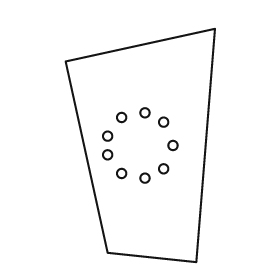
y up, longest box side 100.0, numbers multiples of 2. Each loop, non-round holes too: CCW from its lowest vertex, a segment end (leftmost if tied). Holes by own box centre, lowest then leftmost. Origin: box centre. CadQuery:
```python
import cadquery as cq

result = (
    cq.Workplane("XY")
    .moveTo(24.0, -50.0)
    .lineTo(32.0, 50.0)
    .lineTo(-32.0, 36.0)
    .lineTo(-14.0, -46.0)
    .close()
    .moveTo(2.0, -14.0)
    .circle(2.0)
    .moveTo(-8.0, -12.0)
    .circle(2.0)
    .moveTo(10.0, -10.0)
    .circle(2.0)
    .moveTo(-14.0, -4.0)
    .circle(2.0)
    .moveTo(14.0, 0.0)
    .circle(2.0)
    .moveTo(-14.0, 4.0)
    .circle(2.0)
    .moveTo(10.0, 10.0)
    .circle(2.0)
    .moveTo(-8.0, 12.0)
    .circle(2.0)
    .moveTo(2.0, 14.0)
    .circle(2.0)
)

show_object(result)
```